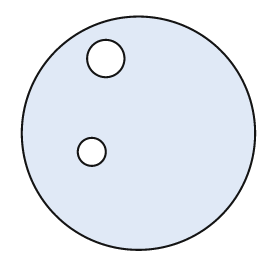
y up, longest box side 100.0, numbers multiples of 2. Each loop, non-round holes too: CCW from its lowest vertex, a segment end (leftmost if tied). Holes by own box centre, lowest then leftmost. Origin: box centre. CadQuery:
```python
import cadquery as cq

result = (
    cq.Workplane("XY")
    .moveTo(0.0, 0.0)
    .circle(50.0)
    .moveTo(-20.0, -8.0)
    .circle(6.0)
    .moveTo(-14.0, 32.0)
    .circle(8.0)
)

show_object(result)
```